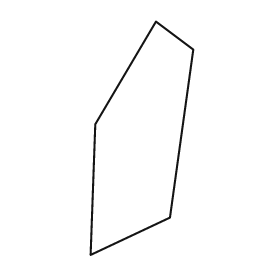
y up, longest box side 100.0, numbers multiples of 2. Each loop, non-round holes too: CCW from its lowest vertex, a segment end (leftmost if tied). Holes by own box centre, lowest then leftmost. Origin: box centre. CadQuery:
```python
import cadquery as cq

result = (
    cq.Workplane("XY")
    .moveTo(-22.0, -50.0)
    .lineTo(12.0, -34.0)
    .lineTo(22.0, 38.0)
    .lineTo(6.0, 50.0)
    .lineTo(-20.0, 6.0)
    .close()
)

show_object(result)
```